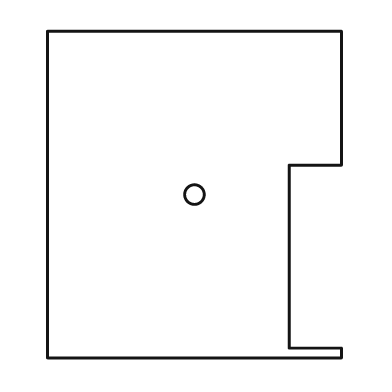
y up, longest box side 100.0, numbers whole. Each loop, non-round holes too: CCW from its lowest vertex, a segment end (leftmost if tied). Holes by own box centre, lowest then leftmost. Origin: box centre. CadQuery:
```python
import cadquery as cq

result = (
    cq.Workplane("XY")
    .moveTo(-45.0, -50.0)
    .lineTo(45.0, -50.0)
    .lineTo(45.0, -47.0)
    .lineTo(29.0, -47.0)
    .lineTo(29.0, 9.0)
    .lineTo(45.0, 9.0)
    .lineTo(45.0, 50.0)
    .lineTo(-45.0, 50.0)
    .close()
    .moveTo(0.0, 0.0)
    .circle(3.0)
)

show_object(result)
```